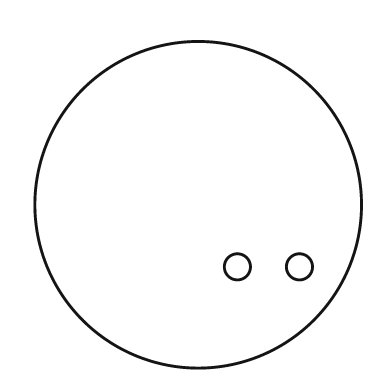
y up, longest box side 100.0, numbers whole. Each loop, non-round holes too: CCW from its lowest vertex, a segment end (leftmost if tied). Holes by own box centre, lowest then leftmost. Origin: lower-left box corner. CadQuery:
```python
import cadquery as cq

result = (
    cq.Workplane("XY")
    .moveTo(50.0, 50.0)
    .circle(50.0)
    .moveTo(62.0, 31.0)
    .circle(4.0)
    .moveTo(81.0, 31.0)
    .circle(4.0)
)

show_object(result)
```